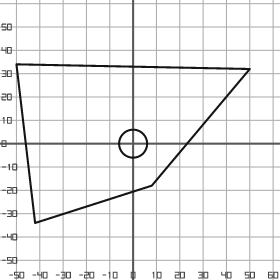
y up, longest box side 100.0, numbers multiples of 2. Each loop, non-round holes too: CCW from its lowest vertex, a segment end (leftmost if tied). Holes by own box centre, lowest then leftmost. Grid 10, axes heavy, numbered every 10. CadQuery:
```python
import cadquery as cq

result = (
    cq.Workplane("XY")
    .moveTo(-42.0, -34.0)
    .lineTo(8.0, -18.0)
    .lineTo(50.0, 32.0)
    .lineTo(-50.0, 34.0)
    .close()
    .moveTo(0.0, 0.0)
    .circle(6.0)
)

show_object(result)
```